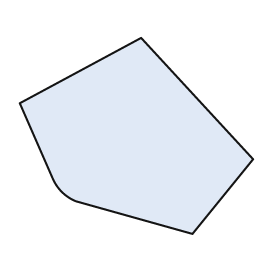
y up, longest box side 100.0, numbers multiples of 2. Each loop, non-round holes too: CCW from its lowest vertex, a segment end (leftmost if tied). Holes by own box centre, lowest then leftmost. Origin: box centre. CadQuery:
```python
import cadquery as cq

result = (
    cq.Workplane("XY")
    .moveTo(24.0, -42.0)
    .lineTo(50.0, -10.0)
    .lineTo(2.0, 42.0)
    .lineTo(-50.0, 14.0)
    .lineTo(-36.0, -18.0)
    .threePointArc((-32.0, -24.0), (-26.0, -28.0))
    .close()
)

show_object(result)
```